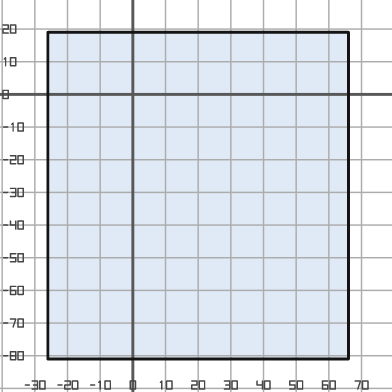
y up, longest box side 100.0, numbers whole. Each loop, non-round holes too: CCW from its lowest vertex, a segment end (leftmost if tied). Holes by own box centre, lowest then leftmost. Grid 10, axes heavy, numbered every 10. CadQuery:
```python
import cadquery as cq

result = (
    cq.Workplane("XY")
    .moveTo(-26.0, -81.0)
    .lineTo(66.0, -81.0)
    .lineTo(66.0, 19.0)
    .lineTo(-26.0, 19.0)
    .close()
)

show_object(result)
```